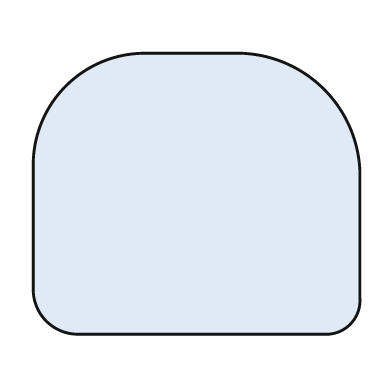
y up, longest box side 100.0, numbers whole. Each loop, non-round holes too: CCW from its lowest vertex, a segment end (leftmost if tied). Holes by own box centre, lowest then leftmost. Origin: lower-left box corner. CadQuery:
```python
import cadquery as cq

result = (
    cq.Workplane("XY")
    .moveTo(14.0, 0.0)
    .lineTo(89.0, 0.0)
    .threePointArc((97.0, 3.0), (100.0, 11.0))
    .lineTo(100.0, 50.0)
    .threePointArc((89.0, 75.0), (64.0, 86.0))
    .lineTo(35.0, 86.0)
    .threePointArc((10.0, 76.0), (0.0, 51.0))
    .lineTo(0.0, 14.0)
    .threePointArc((4.0, 4.0), (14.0, 0.0))
    .close()
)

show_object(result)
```